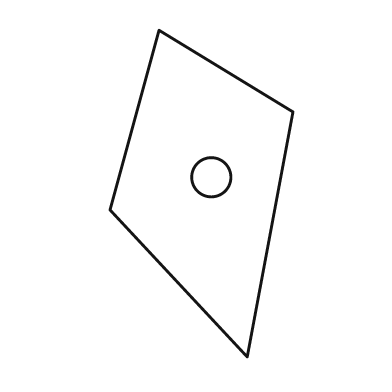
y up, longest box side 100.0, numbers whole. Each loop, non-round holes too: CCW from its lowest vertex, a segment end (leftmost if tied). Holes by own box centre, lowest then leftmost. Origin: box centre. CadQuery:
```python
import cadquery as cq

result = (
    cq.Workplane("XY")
    .moveTo(14.0, -50.0)
    .lineTo(28.0, 25.0)
    .lineTo(-13.0, 50.0)
    .lineTo(-28.0, -5.0)
    .close()
    .moveTo(3.0, 5.0)
    .circle(6.0)
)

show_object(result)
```